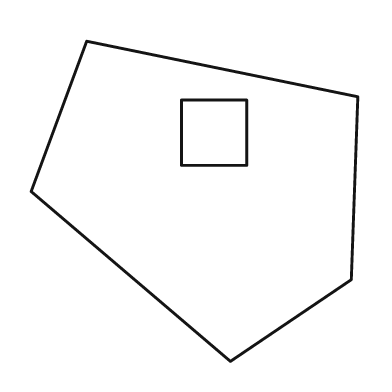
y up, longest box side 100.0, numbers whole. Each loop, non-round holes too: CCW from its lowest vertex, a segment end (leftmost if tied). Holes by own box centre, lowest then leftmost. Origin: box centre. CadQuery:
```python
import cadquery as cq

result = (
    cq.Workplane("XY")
    .moveTo(11.0, -49.0)
    .lineTo(48.0, -24.0)
    .lineTo(50.0, 32.0)
    .lineTo(-33.0, 49.0)
    .lineTo(-50.0, 3.0)
    .close()
    .moveTo(-4.0, 11.0)
    .lineTo(16.0, 11.0)
    .lineTo(16.0, 31.0)
    .lineTo(-4.0, 31.0)
    .close()
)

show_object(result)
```